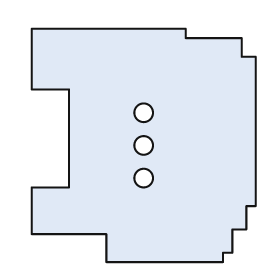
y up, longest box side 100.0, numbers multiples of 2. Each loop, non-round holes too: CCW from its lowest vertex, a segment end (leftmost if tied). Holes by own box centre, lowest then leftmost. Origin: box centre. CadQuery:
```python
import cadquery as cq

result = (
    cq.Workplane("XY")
    .moveTo(-16.0, -50.0)
    .lineTo(34.0, -50.0)
    .lineTo(34.0, -46.0)
    .lineTo(38.0, -46.0)
    .lineTo(38.0, -36.0)
    .lineTo(44.0, -36.0)
    .lineTo(44.0, -26.0)
    .lineTo(48.0, -26.0)
    .lineTo(48.0, 38.0)
    .lineTo(42.0, 38.0)
    .lineTo(42.0, 46.0)
    .lineTo(18.0, 46.0)
    .lineTo(18.0, 50.0)
    .lineTo(-48.0, 50.0)
    .lineTo(-48.0, 24.0)
    .lineTo(-32.0, 24.0)
    .lineTo(-32.0, -18.0)
    .lineTo(-48.0, -18.0)
    .lineTo(-48.0, -38.0)
    .lineTo(-16.0, -38.0)
    .close()
    .moveTo(0.0, -14.0)
    .circle(4.0)
    .moveTo(0.0, 0.0)
    .circle(4.0)
    .moveTo(0.0, 14.0)
    .circle(4.0)
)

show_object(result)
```